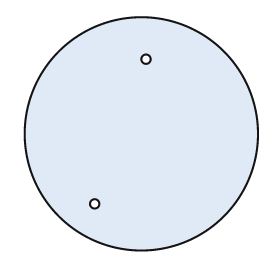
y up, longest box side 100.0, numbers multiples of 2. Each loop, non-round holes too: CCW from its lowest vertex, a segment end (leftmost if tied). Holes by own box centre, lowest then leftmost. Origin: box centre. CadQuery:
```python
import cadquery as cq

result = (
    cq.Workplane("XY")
    .moveTo(0.0, 0.0)
    .circle(50.0)
    .moveTo(-20.0, -30.0)
    .circle(2.0)
    .moveTo(2.0, 32.0)
    .circle(2.0)
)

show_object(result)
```